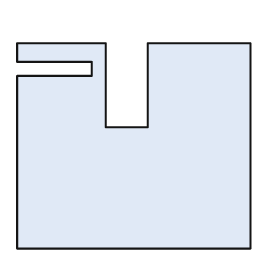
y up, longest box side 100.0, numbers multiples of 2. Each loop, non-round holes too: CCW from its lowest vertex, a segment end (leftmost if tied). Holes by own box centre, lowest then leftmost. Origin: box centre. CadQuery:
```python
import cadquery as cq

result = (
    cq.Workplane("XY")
    .moveTo(-50.0, -44.0)
    .lineTo(50.0, -44.0)
    .lineTo(50.0, 44.0)
    .lineTo(6.0, 44.0)
    .lineTo(6.0, 8.0)
    .lineTo(-12.0, 8.0)
    .lineTo(-12.0, 44.0)
    .lineTo(-50.0, 44.0)
    .lineTo(-50.0, 36.0)
    .lineTo(-18.0, 36.0)
    .lineTo(-18.0, 30.0)
    .lineTo(-50.0, 30.0)
    .close()
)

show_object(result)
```